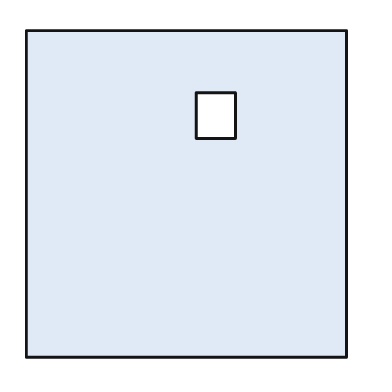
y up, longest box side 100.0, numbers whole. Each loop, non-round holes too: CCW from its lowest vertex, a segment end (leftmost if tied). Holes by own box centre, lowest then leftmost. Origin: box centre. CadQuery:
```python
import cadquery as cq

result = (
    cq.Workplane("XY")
    .moveTo(-49.0, -50.0)
    .lineTo(49.0, -50.0)
    .lineTo(49.0, 50.0)
    .lineTo(-49.0, 50.0)
    .close()
    .moveTo(3.0, 17.0)
    .lineTo(15.0, 17.0)
    .lineTo(15.0, 31.0)
    .lineTo(3.0, 31.0)
    .close()
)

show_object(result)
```